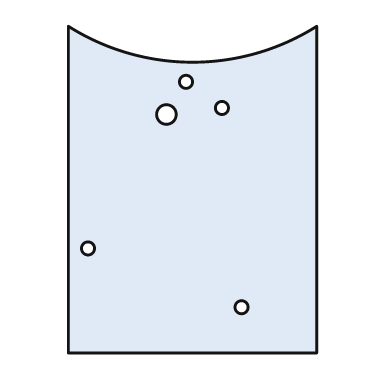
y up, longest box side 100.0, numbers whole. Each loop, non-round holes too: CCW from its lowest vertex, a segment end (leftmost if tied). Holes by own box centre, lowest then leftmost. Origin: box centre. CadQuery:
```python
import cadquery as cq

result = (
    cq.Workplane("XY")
    .moveTo(-38.0, -50.0)
    .lineTo(38.0, -50.0)
    .lineTo(38.0, 50.0)
    .threePointArc((0.0, 39.0), (-38.0, 50.0))
    .close()
    .moveTo(15.0, -36.0)
    .circle(2.0)
    .moveTo(-32.0, -18.0)
    .circle(2.0)
    .moveTo(-8.0, 23.0)
    .circle(3.0)
    .moveTo(9.0, 25.0)
    .circle(2.0)
    .moveTo(-2.0, 33.0)
    .circle(2.0)
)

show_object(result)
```